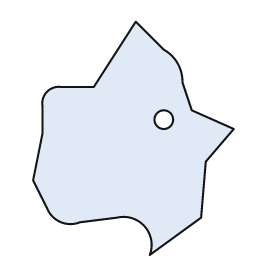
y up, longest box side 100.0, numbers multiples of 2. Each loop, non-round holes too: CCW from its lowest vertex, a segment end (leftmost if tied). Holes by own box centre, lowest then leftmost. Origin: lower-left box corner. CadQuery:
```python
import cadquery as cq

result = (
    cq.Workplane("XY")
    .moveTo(50.0, 0.0)
    .lineTo(72.0, 16.0)
    .lineTo(74.0, 40.0)
    .lineTo(86.0, 54.0)
    .lineTo(68.0, 62.0)
    .lineTo(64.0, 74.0)
    .threePointArc((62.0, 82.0), (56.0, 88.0))
    .lineTo(44.0, 100.0)
    .lineTo(26.0, 72.0)
    .lineTo(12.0, 72.0)
    .threePointArc((6.0, 70.0), (4.0, 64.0))
    .lineTo(4.0, 52.0)
    .lineTo(0.0, 32.0)
    .lineTo(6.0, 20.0)
    .threePointArc((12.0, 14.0), (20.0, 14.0))
    .lineTo(36.0, 16.0)
    .threePointArc((48.0, 12.0), (50.0, 0.0))
    .close()
    .moveTo(56.0, 58.0)
    .circle(4.0)
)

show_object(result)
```